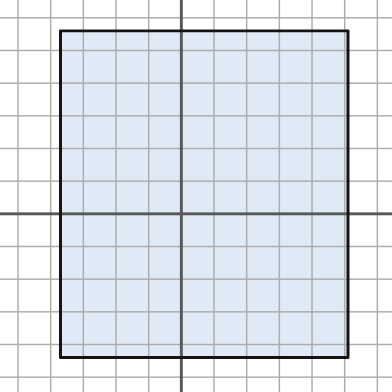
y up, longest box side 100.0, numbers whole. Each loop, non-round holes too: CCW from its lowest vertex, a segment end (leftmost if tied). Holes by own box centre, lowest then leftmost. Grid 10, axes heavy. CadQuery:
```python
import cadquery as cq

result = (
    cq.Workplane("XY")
    .moveTo(-37.0, -44.0)
    .lineTo(51.0, -44.0)
    .lineTo(51.0, 56.0)
    .lineTo(-37.0, 56.0)
    .close()
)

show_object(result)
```